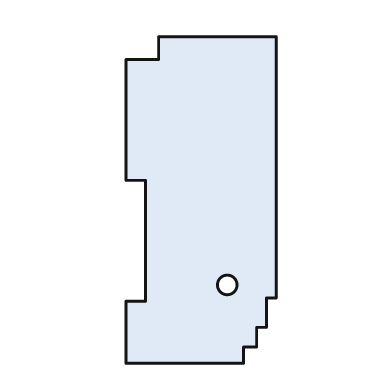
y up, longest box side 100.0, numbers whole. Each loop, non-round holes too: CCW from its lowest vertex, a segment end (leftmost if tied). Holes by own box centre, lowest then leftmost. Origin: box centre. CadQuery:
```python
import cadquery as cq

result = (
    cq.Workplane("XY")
    .moveTo(-23.0, -50.0)
    .lineTo(13.0, -50.0)
    .lineTo(13.0, -45.0)
    .lineTo(17.0, -45.0)
    .lineTo(17.0, -39.0)
    .lineTo(20.0, -39.0)
    .lineTo(20.0, -30.0)
    .lineTo(23.0, -30.0)
    .lineTo(23.0, 50.0)
    .lineTo(-13.0, 50.0)
    .lineTo(-13.0, 43.0)
    .lineTo(-23.0, 43.0)
    .lineTo(-23.0, 6.0)
    .lineTo(-17.0, 6.0)
    .lineTo(-17.0, -31.0)
    .lineTo(-23.0, -31.0)
    .close()
    .moveTo(8.0, -26.0)
    .circle(3.0)
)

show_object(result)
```